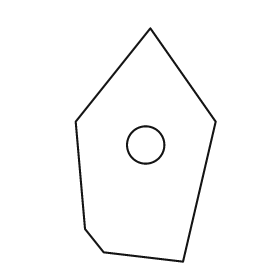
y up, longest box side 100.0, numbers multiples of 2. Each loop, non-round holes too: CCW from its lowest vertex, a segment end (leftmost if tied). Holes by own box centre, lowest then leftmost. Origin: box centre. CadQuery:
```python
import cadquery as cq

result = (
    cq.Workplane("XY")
    .moveTo(16.0, -50.0)
    .lineTo(30.0, 10.0)
    .lineTo(2.0, 50.0)
    .lineTo(-30.0, 10.0)
    .lineTo(-26.0, -36.0)
    .lineTo(-18.0, -46.0)
    .close()
    .moveTo(0.0, 0.0)
    .circle(8.0)
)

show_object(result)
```